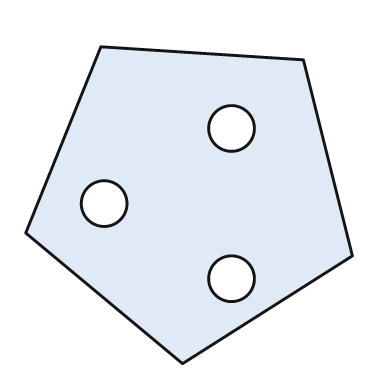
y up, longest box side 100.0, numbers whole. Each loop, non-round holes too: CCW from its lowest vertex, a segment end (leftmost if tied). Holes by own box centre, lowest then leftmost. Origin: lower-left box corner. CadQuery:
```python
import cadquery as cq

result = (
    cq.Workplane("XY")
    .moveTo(48.0, 0.0)
    .lineTo(100.0, 33.0)
    .lineTo(85.0, 93.0)
    .lineTo(23.0, 97.0)
    .lineTo(0.0, 40.0)
    .close()
    .moveTo(63.0, 26.0)
    .circle(7.0)
    .moveTo(24.0, 49.0)
    .circle(7.0)
    .moveTo(63.0, 72.0)
    .circle(7.0)
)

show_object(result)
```